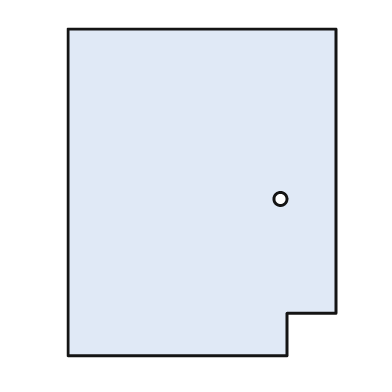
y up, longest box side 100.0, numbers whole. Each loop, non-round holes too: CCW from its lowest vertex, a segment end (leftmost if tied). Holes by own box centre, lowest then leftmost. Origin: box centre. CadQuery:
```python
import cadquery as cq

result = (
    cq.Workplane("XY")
    .moveTo(-41.0, -50.0)
    .lineTo(26.0, -50.0)
    .lineTo(26.0, -37.0)
    .lineTo(41.0, -37.0)
    .lineTo(41.0, 50.0)
    .lineTo(-41.0, 50.0)
    .close()
    .moveTo(24.0, -2.0)
    .circle(2.0)
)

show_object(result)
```